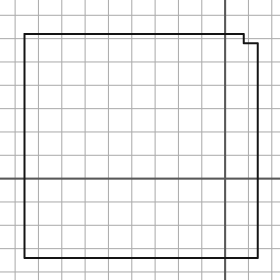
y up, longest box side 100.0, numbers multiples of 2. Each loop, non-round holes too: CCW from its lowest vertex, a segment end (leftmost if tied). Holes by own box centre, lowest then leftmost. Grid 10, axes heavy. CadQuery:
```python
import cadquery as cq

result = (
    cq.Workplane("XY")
    .moveTo(-86.0, -34.0)
    .lineTo(14.0, -34.0)
    .lineTo(14.0, 58.0)
    .lineTo(8.0, 58.0)
    .lineTo(8.0, 62.0)
    .lineTo(-86.0, 62.0)
    .close()
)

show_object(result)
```